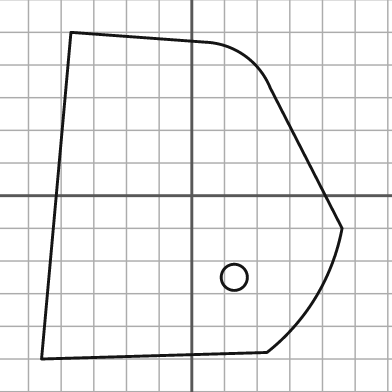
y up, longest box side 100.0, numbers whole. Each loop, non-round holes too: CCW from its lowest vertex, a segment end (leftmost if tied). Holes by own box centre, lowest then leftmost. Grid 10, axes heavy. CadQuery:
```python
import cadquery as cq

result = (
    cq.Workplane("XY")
    .moveTo(-46.0, -50.0)
    .lineTo(23.0, -48.0)
    .threePointArc((38.0, -31.0), (46.0, -10.0))
    .lineTo(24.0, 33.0)
    .threePointArc((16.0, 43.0), (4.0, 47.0))
    .lineTo(-37.0, 50.0)
    .close()
    .moveTo(13.0, -25.0)
    .circle(4.0)
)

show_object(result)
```